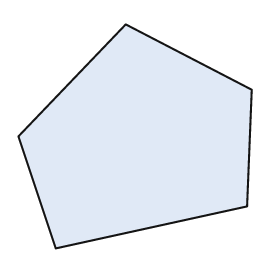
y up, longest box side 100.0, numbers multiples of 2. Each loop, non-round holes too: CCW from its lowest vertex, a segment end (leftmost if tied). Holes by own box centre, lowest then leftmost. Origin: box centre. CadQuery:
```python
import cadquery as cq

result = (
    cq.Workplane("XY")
    .moveTo(-34.0, -48.0)
    .lineTo(48.0, -30.0)
    .lineTo(50.0, 20.0)
    .lineTo(-4.0, 48.0)
    .lineTo(-50.0, 0.0)
    .close()
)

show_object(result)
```